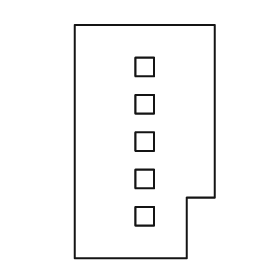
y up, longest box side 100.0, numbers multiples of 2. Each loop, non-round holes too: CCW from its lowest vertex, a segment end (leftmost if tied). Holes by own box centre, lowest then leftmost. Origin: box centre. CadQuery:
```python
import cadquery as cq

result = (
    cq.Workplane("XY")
    .moveTo(-30.0, -50.0)
    .lineTo(18.0, -50.0)
    .lineTo(18.0, -24.0)
    .lineTo(30.0, -24.0)
    .lineTo(30.0, 50.0)
    .lineTo(-30.0, 50.0)
    .close()
    .moveTo(-4.0, -36.0)
    .lineTo(4.0, -36.0)
    .lineTo(4.0, -28.0)
    .lineTo(-4.0, -28.0)
    .close()
    .moveTo(-4.0, -20.0)
    .lineTo(4.0, -20.0)
    .lineTo(4.0, -12.0)
    .lineTo(-4.0, -12.0)
    .close()
    .moveTo(-4.0, -4.0)
    .lineTo(4.0, -4.0)
    .lineTo(4.0, 4.0)
    .lineTo(-4.0, 4.0)
    .close()
    .moveTo(-4.0, 12.0)
    .lineTo(4.0, 12.0)
    .lineTo(4.0, 20.0)
    .lineTo(-4.0, 20.0)
    .close()
    .moveTo(-4.0, 28.0)
    .lineTo(4.0, 28.0)
    .lineTo(4.0, 36.0)
    .lineTo(-4.0, 36.0)
    .close()
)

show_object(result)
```